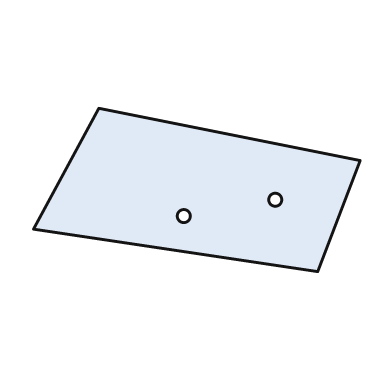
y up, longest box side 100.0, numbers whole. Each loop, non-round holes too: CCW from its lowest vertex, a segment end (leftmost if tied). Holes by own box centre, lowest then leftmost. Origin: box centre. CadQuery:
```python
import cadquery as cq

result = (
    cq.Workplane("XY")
    .moveTo(37.0, -25.0)
    .lineTo(50.0, 9.0)
    .lineTo(-30.0, 25.0)
    .lineTo(-50.0, -12.0)
    .close()
    .moveTo(-4.0, -8.0)
    .circle(2.0)
    .moveTo(24.0, -3.0)
    .circle(2.0)
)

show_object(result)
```